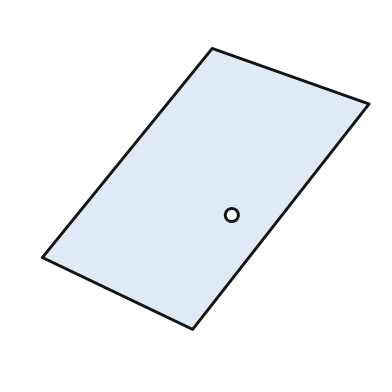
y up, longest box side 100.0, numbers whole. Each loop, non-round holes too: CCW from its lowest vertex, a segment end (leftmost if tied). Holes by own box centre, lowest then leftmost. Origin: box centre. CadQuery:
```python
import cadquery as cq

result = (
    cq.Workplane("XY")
    .moveTo(-4.0, -43.0)
    .lineTo(50.0, 26.0)
    .lineTo(2.0, 43.0)
    .lineTo(-50.0, -21.0)
    .close()
    .moveTo(8.0, -8.0)
    .circle(2.0)
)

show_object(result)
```